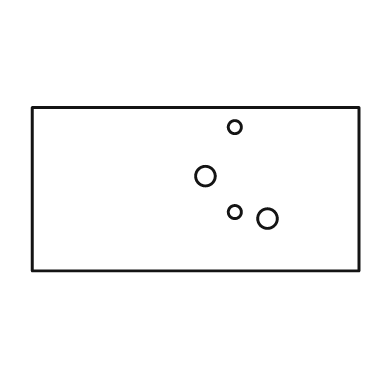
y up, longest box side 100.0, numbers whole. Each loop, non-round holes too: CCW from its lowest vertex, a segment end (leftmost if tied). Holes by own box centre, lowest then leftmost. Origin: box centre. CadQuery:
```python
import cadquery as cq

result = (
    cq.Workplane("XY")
    .moveTo(-50.0, -25.0)
    .lineTo(50.0, -25.0)
    .lineTo(50.0, 25.0)
    .lineTo(-50.0, 25.0)
    .close()
    .moveTo(22.0, -9.0)
    .circle(3.0)
    .moveTo(12.0, -7.0)
    .circle(2.0)
    .moveTo(3.0, 4.0)
    .circle(3.0)
    .moveTo(12.0, 19.0)
    .circle(2.0)
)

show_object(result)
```